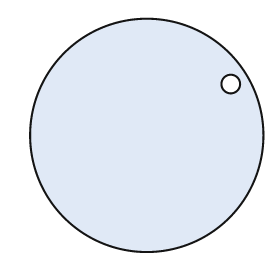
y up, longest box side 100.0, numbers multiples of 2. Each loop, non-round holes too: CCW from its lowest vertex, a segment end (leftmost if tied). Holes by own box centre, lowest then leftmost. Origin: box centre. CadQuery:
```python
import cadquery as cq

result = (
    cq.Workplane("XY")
    .moveTo(0.0, 0.0)
    .circle(50.0)
    .moveTo(36.0, 22.0)
    .circle(4.0)
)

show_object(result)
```